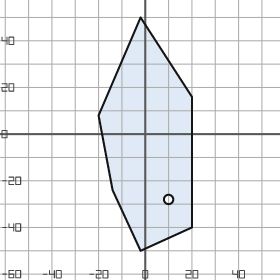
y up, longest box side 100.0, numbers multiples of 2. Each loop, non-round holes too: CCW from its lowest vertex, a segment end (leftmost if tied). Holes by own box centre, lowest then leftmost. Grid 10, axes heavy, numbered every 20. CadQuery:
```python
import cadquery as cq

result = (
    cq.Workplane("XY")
    .moveTo(-2.0, -50.0)
    .lineTo(20.0, -40.0)
    .lineTo(20.0, 16.0)
    .lineTo(-2.0, 50.0)
    .lineTo(-20.0, 8.0)
    .lineTo(-14.0, -24.0)
    .close()
    .moveTo(10.0, -28.0)
    .circle(2.0)
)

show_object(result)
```